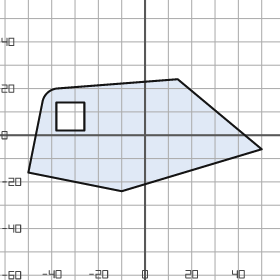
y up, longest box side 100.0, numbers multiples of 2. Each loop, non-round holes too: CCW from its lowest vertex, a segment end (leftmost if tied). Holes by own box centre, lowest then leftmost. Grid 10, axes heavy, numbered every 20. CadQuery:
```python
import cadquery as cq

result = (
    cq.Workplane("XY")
    .moveTo(-10.0, -24.0)
    .lineTo(50.0, -6.0)
    .lineTo(14.0, 24.0)
    .lineTo(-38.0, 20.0)
    .threePointArc((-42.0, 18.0), (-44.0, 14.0))
    .lineTo(-50.0, -16.0)
    .close()
    .moveTo(-38.0, 2.0)
    .lineTo(-26.0, 2.0)
    .lineTo(-26.0, 14.0)
    .lineTo(-38.0, 14.0)
    .close()
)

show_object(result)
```